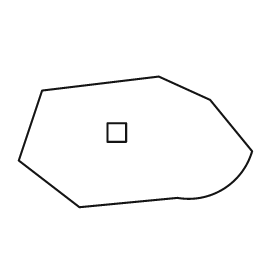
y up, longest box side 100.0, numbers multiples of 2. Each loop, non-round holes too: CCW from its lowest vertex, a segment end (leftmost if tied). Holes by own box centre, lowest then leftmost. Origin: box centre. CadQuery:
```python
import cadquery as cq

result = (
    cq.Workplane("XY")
    .moveTo(-24.0, -28.0)
    .lineTo(18.0, -24.0)
    .threePointArc((38.0, -20.0), (50.0, -4.0))
    .lineTo(32.0, 18.0)
    .lineTo(10.0, 28.0)
    .lineTo(-40.0, 22.0)
    .lineTo(-50.0, -8.0)
    .close()
    .moveTo(-12.0, 0.0)
    .lineTo(-4.0, 0.0)
    .lineTo(-4.0, 8.0)
    .lineTo(-12.0, 8.0)
    .close()
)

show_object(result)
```